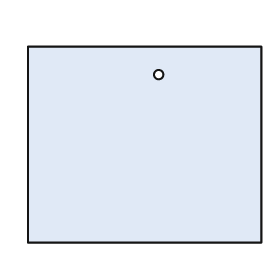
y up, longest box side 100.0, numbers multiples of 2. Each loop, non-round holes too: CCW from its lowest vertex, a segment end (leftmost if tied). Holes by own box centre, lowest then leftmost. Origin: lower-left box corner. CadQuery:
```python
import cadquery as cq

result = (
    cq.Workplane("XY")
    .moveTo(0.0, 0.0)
    .lineTo(100.0, 0.0)
    .lineTo(100.0, 84.0)
    .lineTo(0.0, 84.0)
    .close()
    .moveTo(56.0, 72.0)
    .circle(2.0)
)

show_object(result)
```